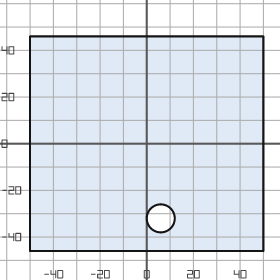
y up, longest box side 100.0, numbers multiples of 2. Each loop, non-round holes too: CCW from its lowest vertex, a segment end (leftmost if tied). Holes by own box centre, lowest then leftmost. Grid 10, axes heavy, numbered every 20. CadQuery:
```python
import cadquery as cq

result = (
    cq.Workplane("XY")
    .moveTo(-50.0, -46.0)
    .lineTo(50.0, -46.0)
    .lineTo(50.0, 46.0)
    .lineTo(-50.0, 46.0)
    .close()
    .moveTo(6.0, -32.0)
    .circle(6.0)
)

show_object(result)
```